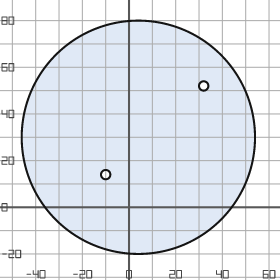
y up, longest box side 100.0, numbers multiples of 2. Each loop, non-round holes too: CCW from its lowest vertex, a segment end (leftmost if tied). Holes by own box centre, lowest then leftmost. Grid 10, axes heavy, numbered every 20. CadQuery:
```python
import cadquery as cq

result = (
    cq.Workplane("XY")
    .moveTo(4.0, 30.0)
    .circle(50.0)
    .moveTo(-10.0, 14.0)
    .circle(2.0)
    .moveTo(32.0, 52.0)
    .circle(2.0)
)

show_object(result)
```